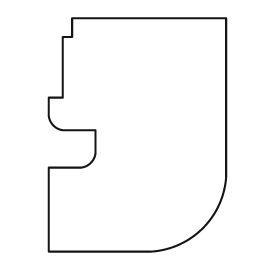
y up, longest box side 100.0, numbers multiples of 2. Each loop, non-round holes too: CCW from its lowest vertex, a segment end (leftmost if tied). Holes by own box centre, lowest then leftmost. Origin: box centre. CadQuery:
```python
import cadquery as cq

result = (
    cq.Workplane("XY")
    .moveTo(-38.0, -50.0)
    .lineTo(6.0, -50.0)
    .threePointArc((28.0, -40.0), (38.0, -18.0))
    .lineTo(38.0, 50.0)
    .lineTo(-28.0, 50.0)
    .lineTo(-28.0, 42.0)
    .lineTo(-32.0, 42.0)
    .lineTo(-32.0, 16.0)
    .lineTo(-38.0, 16.0)
    .lineTo(-38.0, 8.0)
    .threePointArc((-36.0, 4.0), (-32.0, 2.0))
    .lineTo(-18.0, 2.0)
    .lineTo(-18.0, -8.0)
    .threePointArc((-20.0, -12.0), (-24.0, -14.0))
    .lineTo(-38.0, -14.0)
    .close()
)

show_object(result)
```